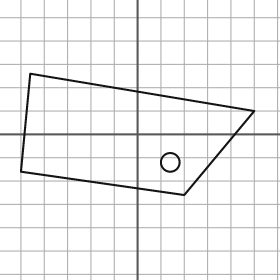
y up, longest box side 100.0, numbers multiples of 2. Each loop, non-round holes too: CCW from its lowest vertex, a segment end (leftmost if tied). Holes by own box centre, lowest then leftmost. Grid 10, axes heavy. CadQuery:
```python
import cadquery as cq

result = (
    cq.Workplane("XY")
    .moveTo(20.0, -26.0)
    .lineTo(50.0, 10.0)
    .lineTo(-46.0, 26.0)
    .lineTo(-50.0, -16.0)
    .close()
    .moveTo(14.0, -12.0)
    .circle(4.0)
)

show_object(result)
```